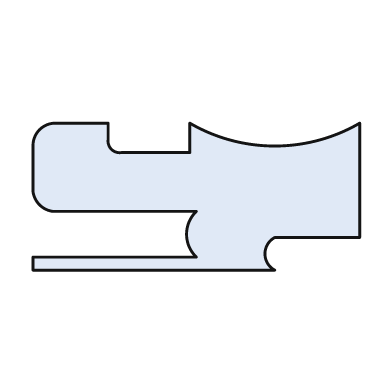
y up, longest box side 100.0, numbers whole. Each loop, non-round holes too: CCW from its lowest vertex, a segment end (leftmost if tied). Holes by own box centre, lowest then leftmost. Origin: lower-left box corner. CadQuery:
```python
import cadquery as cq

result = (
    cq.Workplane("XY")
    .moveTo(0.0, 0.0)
    .lineTo(74.0, 0.0)
    .threePointArc((71.0, 5.0), (74.0, 10.0))
    .lineTo(100.0, 10.0)
    .lineTo(100.0, 45.0)
    .threePointArc((74.0, 38.0), (48.0, 45.0))
    .lineTo(48.0, 36.0)
    .lineTo(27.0, 36.0)
    .threePointArc((24.0, 37.0), (23.0, 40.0))
    .lineTo(23.0, 45.0)
    .lineTo(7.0, 45.0)
    .threePointArc((2.0, 43.0), (0.0, 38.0))
    .lineTo(0.0, 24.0)
    .threePointArc((2.0, 20.0), (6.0, 18.0))
    .lineTo(50.0, 18.0)
    .threePointArc((47.0, 11.0), (50.0, 4.0))
    .lineTo(0.0, 4.0)
    .close()
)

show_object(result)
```